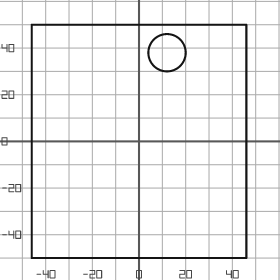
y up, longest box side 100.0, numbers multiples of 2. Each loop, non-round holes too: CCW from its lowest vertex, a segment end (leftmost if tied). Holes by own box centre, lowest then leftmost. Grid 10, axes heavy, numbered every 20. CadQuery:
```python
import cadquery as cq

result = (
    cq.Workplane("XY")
    .moveTo(-46.0, -50.0)
    .lineTo(46.0, -50.0)
    .lineTo(46.0, 50.0)
    .lineTo(-46.0, 50.0)
    .close()
    .moveTo(12.0, 38.0)
    .circle(8.0)
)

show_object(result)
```